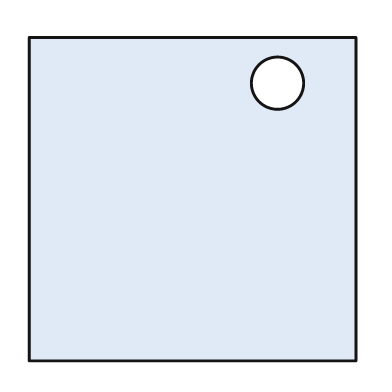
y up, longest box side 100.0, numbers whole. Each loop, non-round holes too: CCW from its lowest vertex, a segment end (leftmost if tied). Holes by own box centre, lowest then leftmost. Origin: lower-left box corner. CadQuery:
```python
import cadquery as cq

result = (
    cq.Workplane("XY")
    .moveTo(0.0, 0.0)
    .lineTo(100.0, 0.0)
    .lineTo(100.0, 99.0)
    .lineTo(0.0, 99.0)
    .close()
    .moveTo(76.0, 85.0)
    .circle(8.0)
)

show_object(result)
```